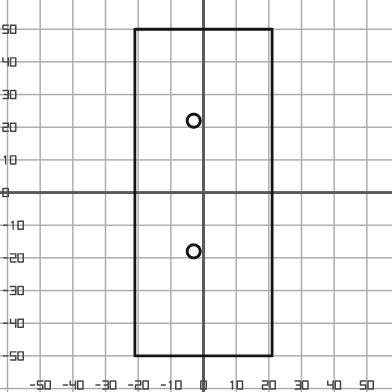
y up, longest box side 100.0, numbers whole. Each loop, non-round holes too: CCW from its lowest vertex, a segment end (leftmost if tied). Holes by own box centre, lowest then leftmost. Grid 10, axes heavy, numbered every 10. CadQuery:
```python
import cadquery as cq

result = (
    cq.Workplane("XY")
    .moveTo(-21.0, -50.0)
    .lineTo(21.0, -50.0)
    .lineTo(21.0, 50.0)
    .lineTo(-21.0, 50.0)
    .close()
    .moveTo(-3.0, -18.0)
    .circle(2.0)
    .moveTo(-3.0, 22.0)
    .circle(2.0)
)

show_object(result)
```